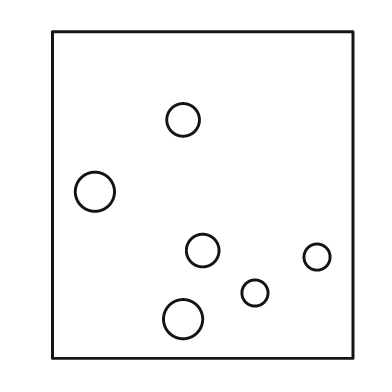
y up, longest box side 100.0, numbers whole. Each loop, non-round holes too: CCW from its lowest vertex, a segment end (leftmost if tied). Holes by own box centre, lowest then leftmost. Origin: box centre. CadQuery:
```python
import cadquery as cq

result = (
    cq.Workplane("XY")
    .moveTo(-46.0, -50.0)
    .lineTo(46.0, -50.0)
    .lineTo(46.0, 50.0)
    .lineTo(-46.0, 50.0)
    .close()
    .moveTo(-6.0, -38.0)
    .circle(6.0)
    .moveTo(16.0, -30.0)
    .circle(4.0)
    .moveTo(35.0, -19.0)
    .circle(4.0)
    .moveTo(0.0, -17.0)
    .circle(5.0)
    .moveTo(-33.0, 1.0)
    .circle(6.0)
    .moveTo(-6.0, 23.0)
    .circle(5.0)
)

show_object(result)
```